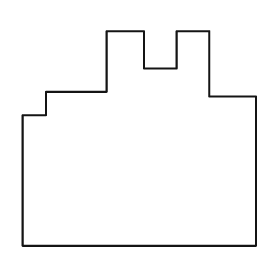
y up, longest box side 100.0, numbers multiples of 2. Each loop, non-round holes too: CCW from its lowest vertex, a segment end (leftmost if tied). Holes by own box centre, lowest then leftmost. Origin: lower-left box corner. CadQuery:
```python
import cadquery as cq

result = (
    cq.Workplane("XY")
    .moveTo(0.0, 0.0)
    .lineTo(100.0, 0.0)
    .lineTo(100.0, 64.0)
    .lineTo(80.0, 64.0)
    .lineTo(80.0, 92.0)
    .lineTo(66.0, 92.0)
    .lineTo(66.0, 76.0)
    .lineTo(52.0, 76.0)
    .lineTo(52.0, 92.0)
    .lineTo(36.0, 92.0)
    .lineTo(36.0, 66.0)
    .lineTo(10.0, 66.0)
    .lineTo(10.0, 56.0)
    .lineTo(0.0, 56.0)
    .close()
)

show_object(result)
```